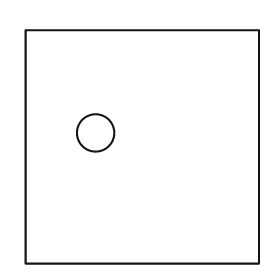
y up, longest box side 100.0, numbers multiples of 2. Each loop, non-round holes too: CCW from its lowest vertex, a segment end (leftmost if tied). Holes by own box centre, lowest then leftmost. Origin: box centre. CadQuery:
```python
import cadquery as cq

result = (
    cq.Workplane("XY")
    .moveTo(-50.0, -50.0)
    .lineTo(50.0, -50.0)
    .lineTo(50.0, 50.0)
    .lineTo(-50.0, 50.0)
    .close()
    .moveTo(-20.0, 6.0)
    .circle(8.0)
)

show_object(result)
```